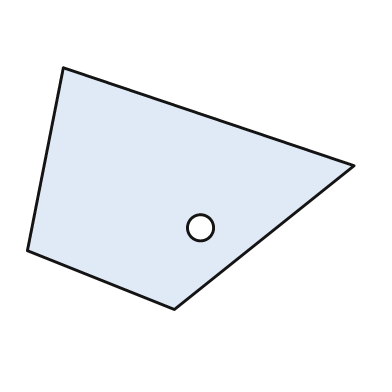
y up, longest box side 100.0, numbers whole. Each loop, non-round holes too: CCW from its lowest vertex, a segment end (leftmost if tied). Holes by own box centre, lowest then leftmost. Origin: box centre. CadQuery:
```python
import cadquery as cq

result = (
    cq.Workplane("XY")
    .moveTo(-5.0, -37.0)
    .lineTo(50.0, 7.0)
    .lineTo(-39.0, 37.0)
    .lineTo(-50.0, -19.0)
    .close()
    .moveTo(3.0, -12.0)
    .circle(4.0)
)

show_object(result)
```